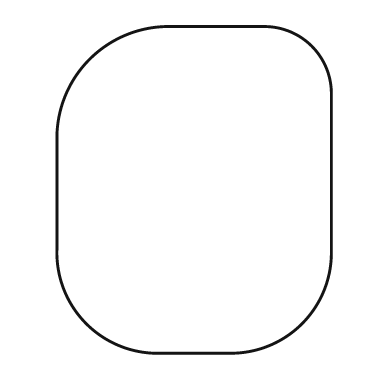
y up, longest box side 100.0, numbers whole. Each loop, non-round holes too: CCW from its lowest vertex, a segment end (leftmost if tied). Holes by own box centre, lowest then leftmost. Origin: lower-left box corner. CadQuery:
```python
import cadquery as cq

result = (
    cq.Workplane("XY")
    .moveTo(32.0, 0.0)
    .lineTo(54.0, 0.0)
    .threePointArc((75.0, 9.0), (84.0, 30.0))
    .lineTo(84.0, 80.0)
    .threePointArc((78.0, 94.0), (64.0, 100.0))
    .lineTo(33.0, 100.0)
    .threePointArc((10.0, 90.0), (0.0, 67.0))
    .lineTo(0.0, 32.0)
    .threePointArc((9.0, 9.0), (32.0, 0.0))
    .close()
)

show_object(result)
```